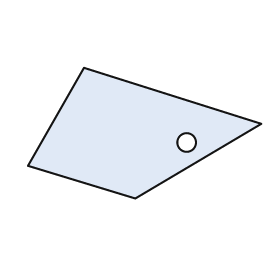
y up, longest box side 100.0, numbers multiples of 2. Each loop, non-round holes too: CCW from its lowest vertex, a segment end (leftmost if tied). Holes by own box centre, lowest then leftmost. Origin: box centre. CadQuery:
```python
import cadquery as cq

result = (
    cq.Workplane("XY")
    .moveTo(-4.0, -28.0)
    .lineTo(50.0, 4.0)
    .lineTo(-26.0, 28.0)
    .lineTo(-50.0, -14.0)
    .close()
    .moveTo(18.0, -4.0)
    .circle(4.0)
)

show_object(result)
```